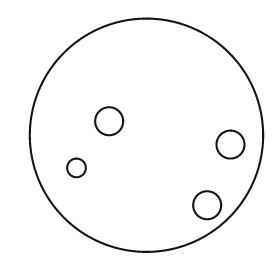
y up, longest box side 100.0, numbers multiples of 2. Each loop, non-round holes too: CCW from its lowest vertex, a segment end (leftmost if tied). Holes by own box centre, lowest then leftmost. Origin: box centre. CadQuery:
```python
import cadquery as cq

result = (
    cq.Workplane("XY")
    .moveTo(0.0, 0.0)
    .circle(50.0)
    .moveTo(26.0, -30.0)
    .circle(6.0)
    .moveTo(-30.0, -14.0)
    .circle(4.0)
    .moveTo(36.0, -4.0)
    .circle(6.0)
    .moveTo(-16.0, 6.0)
    .circle(6.0)
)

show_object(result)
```